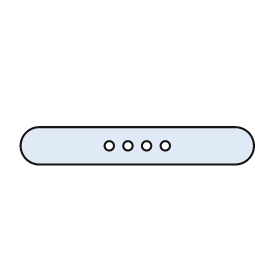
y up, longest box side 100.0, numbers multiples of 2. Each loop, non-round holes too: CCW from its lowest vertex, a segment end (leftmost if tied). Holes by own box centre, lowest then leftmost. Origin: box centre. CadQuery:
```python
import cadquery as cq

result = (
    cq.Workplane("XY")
    .moveTo(-42.0, -8.0)
    .lineTo(42.0, -8.0)
    .threePointArc((50.0, 0.0), (42.0, 8.0))
    .lineTo(-42.0, 8.0)
    .threePointArc((-50.0, 0.0), (-42.0, -8.0))
    .close()
    .moveTo(-12.0, 0.0)
    .circle(2.0)
    .moveTo(-4.0, 0.0)
    .circle(2.0)
    .moveTo(4.0, 0.0)
    .circle(2.0)
    .moveTo(12.0, 0.0)
    .circle(2.0)
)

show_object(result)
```